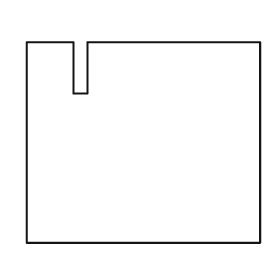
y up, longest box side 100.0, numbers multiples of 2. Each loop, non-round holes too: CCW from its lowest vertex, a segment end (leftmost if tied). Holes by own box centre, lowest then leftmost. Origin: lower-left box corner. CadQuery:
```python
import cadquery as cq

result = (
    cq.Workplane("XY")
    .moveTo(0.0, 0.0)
    .lineTo(100.0, 0.0)
    .lineTo(100.0, 86.0)
    .lineTo(26.0, 86.0)
    .lineTo(26.0, 64.0)
    .lineTo(20.0, 64.0)
    .lineTo(20.0, 86.0)
    .lineTo(0.0, 86.0)
    .close()
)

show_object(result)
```